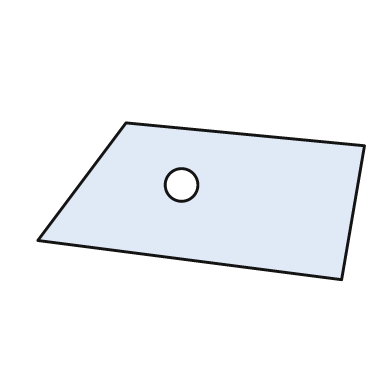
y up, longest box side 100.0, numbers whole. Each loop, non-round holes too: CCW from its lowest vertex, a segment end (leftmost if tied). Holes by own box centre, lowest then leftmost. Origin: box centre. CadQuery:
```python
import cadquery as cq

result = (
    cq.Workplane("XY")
    .moveTo(43.0, -24.0)
    .lineTo(50.0, 17.0)
    .lineTo(-23.0, 24.0)
    .lineTo(-50.0, -12.0)
    .close()
    .moveTo(-6.0, 5.0)
    .circle(5.0)
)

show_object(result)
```